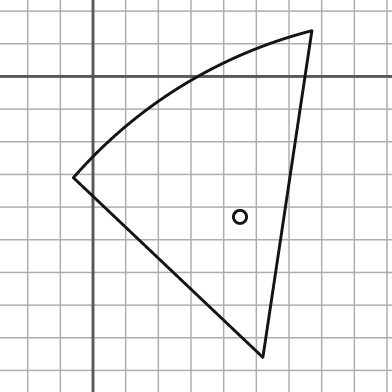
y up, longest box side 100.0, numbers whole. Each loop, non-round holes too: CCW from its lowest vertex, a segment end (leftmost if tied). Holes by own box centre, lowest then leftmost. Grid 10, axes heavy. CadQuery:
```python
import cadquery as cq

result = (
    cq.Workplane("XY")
    .moveTo(52.0, -86.0)
    .lineTo(67.0, 14.0)
    .threePointArc((27.0, -3.0), (-6.0, -31.0))
    .close()
    .moveTo(45.0, -43.0)
    .circle(2.0)
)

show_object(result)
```